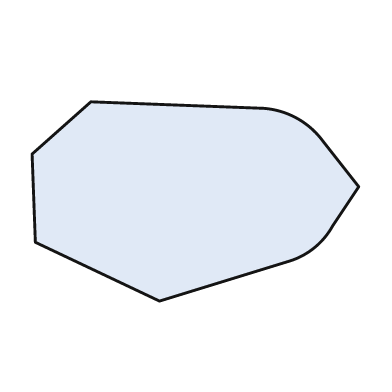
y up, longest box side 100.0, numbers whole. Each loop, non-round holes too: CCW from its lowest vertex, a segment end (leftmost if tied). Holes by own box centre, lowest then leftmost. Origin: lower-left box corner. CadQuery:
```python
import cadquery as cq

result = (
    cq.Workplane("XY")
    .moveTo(39.0, 0.0)
    .lineTo(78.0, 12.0)
    .threePointArc((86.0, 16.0), (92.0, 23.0))
    .lineTo(100.0, 35.0)
    .lineTo(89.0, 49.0)
    .threePointArc((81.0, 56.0), (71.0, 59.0))
    .lineTo(18.0, 61.0)
    .lineTo(0.0, 45.0)
    .lineTo(1.0, 18.0)
    .close()
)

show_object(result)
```